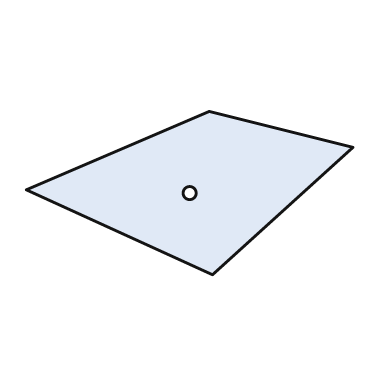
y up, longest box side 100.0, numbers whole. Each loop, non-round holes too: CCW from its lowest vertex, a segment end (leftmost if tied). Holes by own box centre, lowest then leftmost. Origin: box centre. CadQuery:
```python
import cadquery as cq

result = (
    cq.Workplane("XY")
    .moveTo(7.0, -25.0)
    .lineTo(50.0, 14.0)
    .lineTo(6.0, 25.0)
    .lineTo(-50.0, 1.0)
    .close()
    .moveTo(0.0, 0.0)
    .circle(2.0)
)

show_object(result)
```